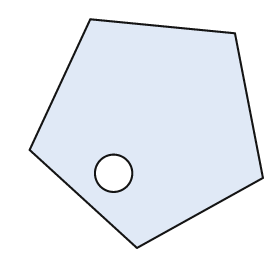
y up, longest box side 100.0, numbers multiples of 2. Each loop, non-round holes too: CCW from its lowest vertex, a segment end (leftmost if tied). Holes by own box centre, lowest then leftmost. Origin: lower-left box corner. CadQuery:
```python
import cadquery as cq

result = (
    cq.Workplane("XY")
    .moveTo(46.0, 0.0)
    .lineTo(100.0, 30.0)
    .lineTo(88.0, 92.0)
    .lineTo(26.0, 98.0)
    .lineTo(0.0, 42.0)
    .close()
    .moveTo(36.0, 32.0)
    .circle(8.0)
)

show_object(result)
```